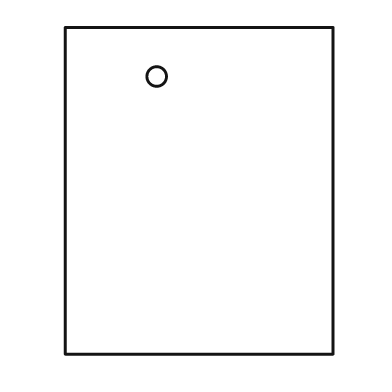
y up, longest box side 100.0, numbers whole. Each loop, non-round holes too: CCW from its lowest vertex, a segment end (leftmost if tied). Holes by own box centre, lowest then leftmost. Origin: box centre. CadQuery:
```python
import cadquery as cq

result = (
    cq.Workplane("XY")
    .moveTo(-41.0, -50.0)
    .lineTo(41.0, -50.0)
    .lineTo(41.0, 50.0)
    .lineTo(-41.0, 50.0)
    .close()
    .moveTo(-13.0, 35.0)
    .circle(3.0)
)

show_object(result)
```